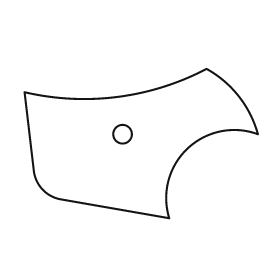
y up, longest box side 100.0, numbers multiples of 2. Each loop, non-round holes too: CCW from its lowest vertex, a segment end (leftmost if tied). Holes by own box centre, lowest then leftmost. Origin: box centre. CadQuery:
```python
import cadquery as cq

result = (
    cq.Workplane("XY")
    .moveTo(12.0, -32.0)
    .threePointArc((20.0, -2.0), (50.0, 4.0))
    .threePointArc((42.0, 20.0), (28.0, 32.0))
    .threePointArc((-10.0, 20.0), (-50.0, 22.0))
    .lineTo(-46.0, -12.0)
    .threePointArc((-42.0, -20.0), (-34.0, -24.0))
    .close()
    .moveTo(-8.0, 4.0)
    .circle(4.0)
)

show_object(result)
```